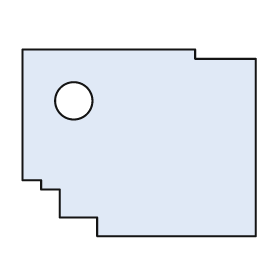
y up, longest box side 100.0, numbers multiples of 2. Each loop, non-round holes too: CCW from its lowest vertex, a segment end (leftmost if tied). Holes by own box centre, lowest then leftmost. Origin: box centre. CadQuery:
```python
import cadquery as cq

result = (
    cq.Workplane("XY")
    .moveTo(-18.0, -40.0)
    .lineTo(50.0, -40.0)
    .lineTo(50.0, 36.0)
    .lineTo(24.0, 36.0)
    .lineTo(24.0, 40.0)
    .lineTo(-50.0, 40.0)
    .lineTo(-50.0, -16.0)
    .lineTo(-42.0, -16.0)
    .lineTo(-42.0, -20.0)
    .lineTo(-34.0, -20.0)
    .lineTo(-34.0, -32.0)
    .lineTo(-18.0, -32.0)
    .close()
    .moveTo(-28.0, 18.0)
    .circle(8.0)
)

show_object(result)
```